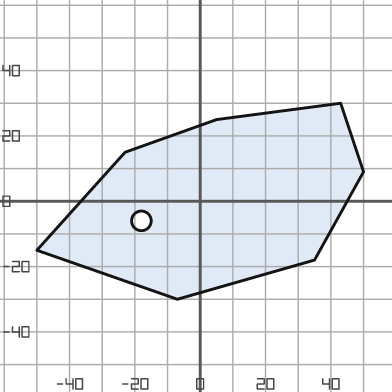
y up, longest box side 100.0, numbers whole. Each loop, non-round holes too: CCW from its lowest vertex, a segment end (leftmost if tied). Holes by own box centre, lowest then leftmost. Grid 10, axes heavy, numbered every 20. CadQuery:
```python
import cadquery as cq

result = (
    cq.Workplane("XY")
    .moveTo(-7.0, -30.0)
    .lineTo(35.0, -18.0)
    .lineTo(50.0, 9.0)
    .lineTo(43.0, 30.0)
    .lineTo(5.0, 25.0)
    .lineTo(-23.0, 15.0)
    .lineTo(-50.0, -15.0)
    .close()
    .moveTo(-18.0, -6.0)
    .circle(3.0)
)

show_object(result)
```